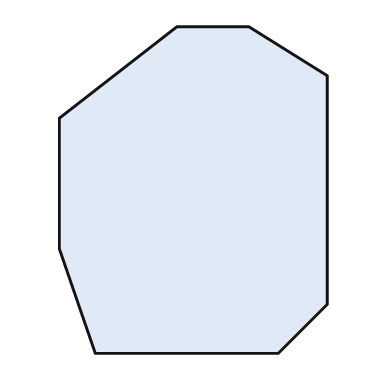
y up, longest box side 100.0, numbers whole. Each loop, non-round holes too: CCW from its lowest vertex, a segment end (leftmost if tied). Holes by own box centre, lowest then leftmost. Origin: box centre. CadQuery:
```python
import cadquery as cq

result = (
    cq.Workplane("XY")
    .moveTo(-30.0, -50.0)
    .lineTo(26.0, -50.0)
    .lineTo(41.0, -35.0)
    .lineTo(41.0, 35.0)
    .lineTo(17.0, 50.0)
    .lineTo(-5.0, 50.0)
    .lineTo(-41.0, 22.0)
    .lineTo(-41.0, -18.0)
    .close()
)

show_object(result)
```